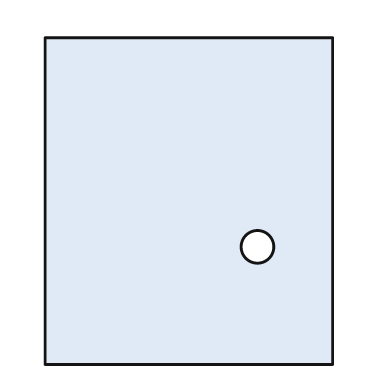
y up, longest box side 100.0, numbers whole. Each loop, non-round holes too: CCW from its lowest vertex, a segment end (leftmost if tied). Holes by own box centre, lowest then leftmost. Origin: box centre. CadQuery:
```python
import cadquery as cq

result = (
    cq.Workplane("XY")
    .moveTo(-44.0, -50.0)
    .lineTo(44.0, -50.0)
    .lineTo(44.0, 50.0)
    .lineTo(-44.0, 50.0)
    .close()
    .moveTo(21.0, -14.0)
    .circle(5.0)
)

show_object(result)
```